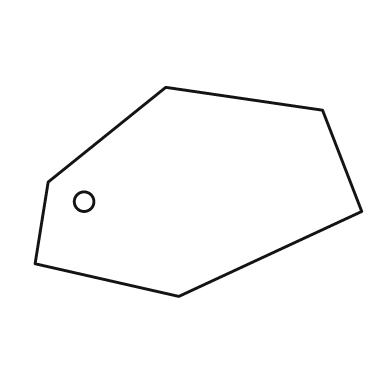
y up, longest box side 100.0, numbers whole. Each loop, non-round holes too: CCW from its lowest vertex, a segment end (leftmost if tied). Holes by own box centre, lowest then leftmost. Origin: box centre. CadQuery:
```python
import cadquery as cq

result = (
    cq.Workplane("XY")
    .moveTo(-6.0, -32.0)
    .lineTo(50.0, -6.0)
    .lineTo(38.0, 25.0)
    .lineTo(-10.0, 32.0)
    .lineTo(-46.0, 3.0)
    .lineTo(-50.0, -22.0)
    .close()
    .moveTo(-35.0, -3.0)
    .circle(3.0)
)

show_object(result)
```